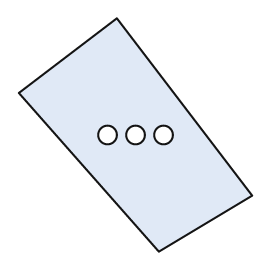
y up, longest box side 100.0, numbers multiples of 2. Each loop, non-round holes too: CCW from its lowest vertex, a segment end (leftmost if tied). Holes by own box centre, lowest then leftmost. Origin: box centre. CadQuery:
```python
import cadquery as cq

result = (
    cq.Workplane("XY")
    .moveTo(10.0, -50.0)
    .lineTo(50.0, -26.0)
    .lineTo(-8.0, 50.0)
    .lineTo(-50.0, 18.0)
    .close()
    .moveTo(-12.0, 0.0)
    .circle(4.0)
    .moveTo(0.0, 0.0)
    .circle(4.0)
    .moveTo(12.0, 0.0)
    .circle(4.0)
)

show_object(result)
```